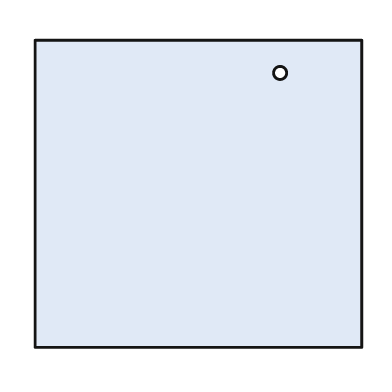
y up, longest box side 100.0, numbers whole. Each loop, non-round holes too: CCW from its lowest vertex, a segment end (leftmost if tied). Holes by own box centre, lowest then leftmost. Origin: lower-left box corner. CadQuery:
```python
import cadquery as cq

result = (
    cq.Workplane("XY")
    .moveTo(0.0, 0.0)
    .lineTo(100.0, 0.0)
    .lineTo(100.0, 94.0)
    .lineTo(0.0, 94.0)
    .close()
    .moveTo(75.0, 84.0)
    .circle(2.0)
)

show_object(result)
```